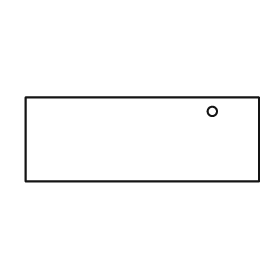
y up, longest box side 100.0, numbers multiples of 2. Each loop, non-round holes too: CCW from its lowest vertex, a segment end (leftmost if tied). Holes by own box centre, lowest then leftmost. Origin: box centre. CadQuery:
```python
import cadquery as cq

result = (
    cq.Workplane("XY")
    .moveTo(-50.0, -18.0)
    .lineTo(50.0, -18.0)
    .lineTo(50.0, 18.0)
    .lineTo(-50.0, 18.0)
    .close()
    .moveTo(30.0, 12.0)
    .circle(2.0)
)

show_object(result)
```